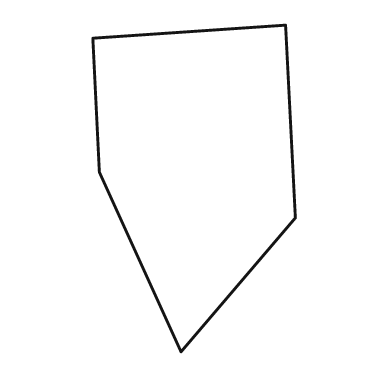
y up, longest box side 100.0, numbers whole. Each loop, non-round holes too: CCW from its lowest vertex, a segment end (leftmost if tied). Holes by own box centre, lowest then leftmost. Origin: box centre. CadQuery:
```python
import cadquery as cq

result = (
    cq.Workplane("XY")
    .moveTo(-4.0, -50.0)
    .lineTo(31.0, -9.0)
    .lineTo(28.0, 50.0)
    .lineTo(-31.0, 46.0)
    .lineTo(-29.0, 5.0)
    .close()
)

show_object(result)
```